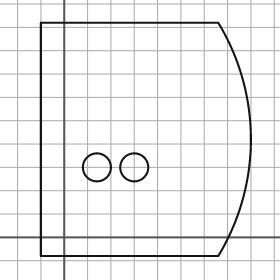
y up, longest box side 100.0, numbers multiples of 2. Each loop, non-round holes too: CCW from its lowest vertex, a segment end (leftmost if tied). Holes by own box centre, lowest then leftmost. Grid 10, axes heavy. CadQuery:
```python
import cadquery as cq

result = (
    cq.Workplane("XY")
    .moveTo(-10.0, -8.0)
    .lineTo(66.0, -8.0)
    .threePointArc((80.0, 42.0), (66.0, 92.0))
    .lineTo(-10.0, 92.0)
    .close()
    .moveTo(14.0, 30.0)
    .circle(6.0)
    .moveTo(30.0, 30.0)
    .circle(6.0)
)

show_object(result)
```